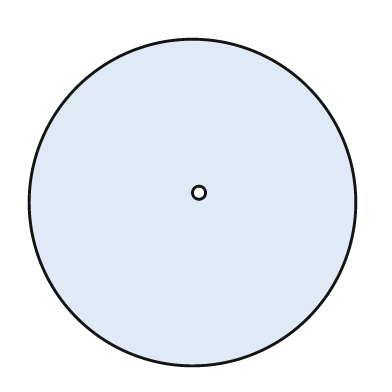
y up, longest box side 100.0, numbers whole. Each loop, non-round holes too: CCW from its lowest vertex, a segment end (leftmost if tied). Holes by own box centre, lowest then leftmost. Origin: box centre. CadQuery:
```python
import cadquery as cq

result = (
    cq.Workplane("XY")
    .moveTo(0.0, 0.0)
    .circle(50.0)
    .moveTo(2.0, 3.0)
    .circle(2.0)
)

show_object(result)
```